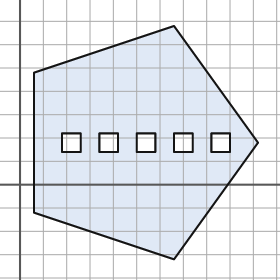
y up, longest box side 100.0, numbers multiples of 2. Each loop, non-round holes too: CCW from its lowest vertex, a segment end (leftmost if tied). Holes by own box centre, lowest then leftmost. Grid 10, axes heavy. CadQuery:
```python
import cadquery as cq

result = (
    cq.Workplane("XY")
    .moveTo(66.0, -32.0)
    .lineTo(102.0, 18.0)
    .lineTo(66.0, 68.0)
    .lineTo(6.0, 48.0)
    .lineTo(6.0, -12.0)
    .close()
    .moveTo(18.0, 14.0)
    .lineTo(26.0, 14.0)
    .lineTo(26.0, 22.0)
    .lineTo(18.0, 22.0)
    .close()
    .moveTo(34.0, 14.0)
    .lineTo(42.0, 14.0)
    .lineTo(42.0, 22.0)
    .lineTo(34.0, 22.0)
    .close()
    .moveTo(50.0, 14.0)
    .lineTo(58.0, 14.0)
    .lineTo(58.0, 22.0)
    .lineTo(50.0, 22.0)
    .close()
    .moveTo(66.0, 14.0)
    .lineTo(74.0, 14.0)
    .lineTo(74.0, 22.0)
    .lineTo(66.0, 22.0)
    .close()
    .moveTo(82.0, 14.0)
    .lineTo(90.0, 14.0)
    .lineTo(90.0, 22.0)
    .lineTo(82.0, 22.0)
    .close()
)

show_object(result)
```